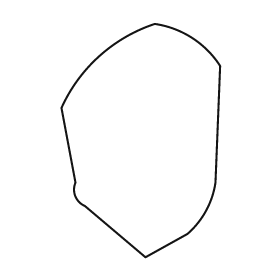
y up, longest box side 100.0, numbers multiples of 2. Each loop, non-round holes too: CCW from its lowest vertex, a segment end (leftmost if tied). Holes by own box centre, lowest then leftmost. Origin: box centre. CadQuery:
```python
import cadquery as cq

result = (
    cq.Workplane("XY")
    .moveTo(2.0, -50.0)
    .lineTo(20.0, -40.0)
    .threePointArc((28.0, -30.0), (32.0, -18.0))
    .lineTo(34.0, 32.0)
    .threePointArc((22.0, 44.0), (6.0, 50.0))
    .threePointArc((-18.0, 36.0), (-34.0, 14.0))
    .lineTo(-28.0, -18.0)
    .threePointArc((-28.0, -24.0), (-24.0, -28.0))
    .close()
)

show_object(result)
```